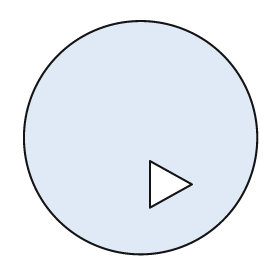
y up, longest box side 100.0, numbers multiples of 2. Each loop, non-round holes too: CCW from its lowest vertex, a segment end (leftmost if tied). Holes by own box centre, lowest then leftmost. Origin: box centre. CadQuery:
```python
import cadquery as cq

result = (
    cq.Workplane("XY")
    .moveTo(0.0, 0.0)
    .circle(50.0)
    .moveTo(4.0, -30.0)
    .lineTo(22.0, -20.0)
    .lineTo(4.0, -10.0)
    .close()
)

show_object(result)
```